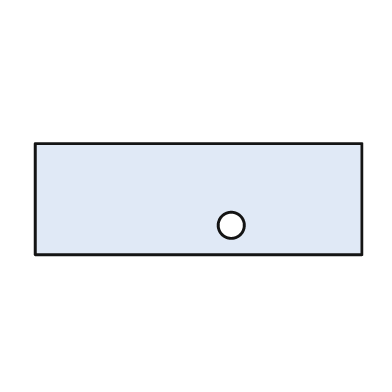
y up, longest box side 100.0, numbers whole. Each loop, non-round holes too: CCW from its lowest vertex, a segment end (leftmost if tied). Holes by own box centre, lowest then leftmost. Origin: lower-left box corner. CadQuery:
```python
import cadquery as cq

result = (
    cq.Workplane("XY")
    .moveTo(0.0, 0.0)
    .lineTo(100.0, 0.0)
    .lineTo(100.0, 34.0)
    .lineTo(0.0, 34.0)
    .close()
    .moveTo(60.0, 9.0)
    .circle(4.0)
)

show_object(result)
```